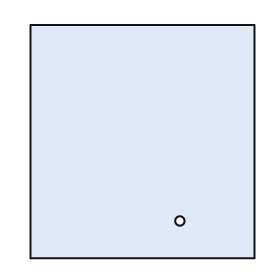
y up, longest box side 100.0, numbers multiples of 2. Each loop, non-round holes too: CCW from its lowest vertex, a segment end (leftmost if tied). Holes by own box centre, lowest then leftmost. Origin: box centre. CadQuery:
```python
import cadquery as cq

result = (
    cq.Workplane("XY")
    .moveTo(-48.0, -50.0)
    .lineTo(48.0, -50.0)
    .lineTo(48.0, 50.0)
    .lineTo(-48.0, 50.0)
    .close()
    .moveTo(16.0, -34.0)
    .circle(2.0)
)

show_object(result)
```